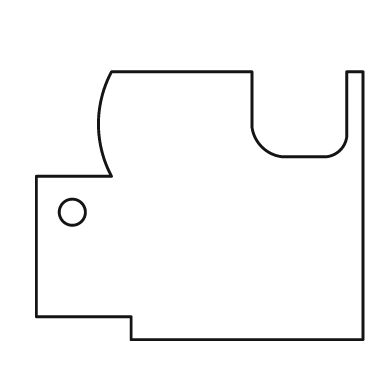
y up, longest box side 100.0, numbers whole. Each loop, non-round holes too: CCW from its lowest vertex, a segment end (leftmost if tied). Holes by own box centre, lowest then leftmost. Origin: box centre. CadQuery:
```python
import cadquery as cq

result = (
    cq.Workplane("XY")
    .moveTo(-21.0, -41.0)
    .lineTo(50.0, -41.0)
    .lineTo(50.0, 41.0)
    .lineTo(45.0, 41.0)
    .lineTo(45.0, 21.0)
    .threePointArc((43.0, 17.0), (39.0, 15.0))
    .lineTo(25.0, 15.0)
    .threePointArc((19.0, 18.0), (16.0, 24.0))
    .lineTo(16.0, 41.0)
    .lineTo(-27.0, 41.0)
    .threePointArc((-31.0, 25.0), (-27.0, 9.0))
    .lineTo(-50.0, 9.0)
    .lineTo(-50.0, -34.0)
    .lineTo(-21.0, -34.0)
    .close()
    .moveTo(-39.0, -2.0)
    .circle(4.0)
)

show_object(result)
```